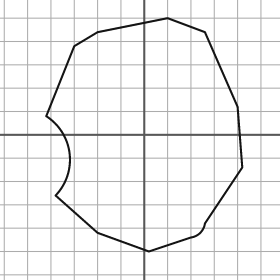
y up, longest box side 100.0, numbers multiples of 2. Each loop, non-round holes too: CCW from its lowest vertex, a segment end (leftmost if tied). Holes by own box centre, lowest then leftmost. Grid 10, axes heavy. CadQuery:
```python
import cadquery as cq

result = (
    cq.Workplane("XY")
    .moveTo(2.0, -50.0)
    .lineTo(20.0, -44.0)
    .threePointArc((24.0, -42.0), (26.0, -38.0))
    .lineTo(42.0, -14.0)
    .lineTo(40.0, 12.0)
    .lineTo(26.0, 44.0)
    .lineTo(10.0, 50.0)
    .lineTo(-20.0, 44.0)
    .lineTo(-30.0, 38.0)
    .lineTo(-42.0, 8.0)
    .threePointArc((-32.0, -8.0), (-38.0, -26.0))
    .lineTo(-20.0, -42.0)
    .close()
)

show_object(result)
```